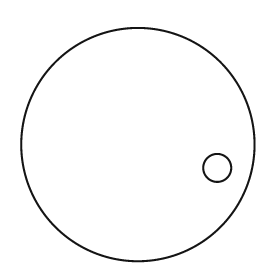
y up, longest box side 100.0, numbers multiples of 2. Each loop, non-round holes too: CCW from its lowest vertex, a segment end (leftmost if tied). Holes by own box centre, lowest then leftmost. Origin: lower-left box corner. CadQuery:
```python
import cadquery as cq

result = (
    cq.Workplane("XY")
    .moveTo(50.0, 50.0)
    .circle(50.0)
    .moveTo(84.0, 40.0)
    .circle(6.0)
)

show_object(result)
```